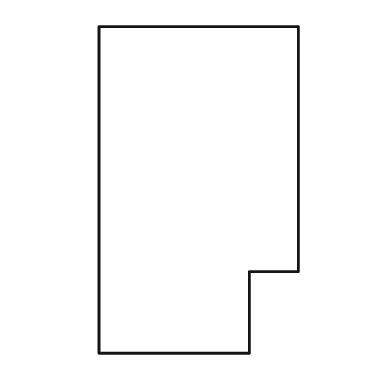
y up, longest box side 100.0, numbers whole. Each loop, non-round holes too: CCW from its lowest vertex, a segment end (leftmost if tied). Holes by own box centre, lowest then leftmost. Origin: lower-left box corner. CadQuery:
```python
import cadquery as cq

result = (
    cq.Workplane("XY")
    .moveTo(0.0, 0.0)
    .lineTo(46.0, 0.0)
    .lineTo(46.0, 25.0)
    .lineTo(61.0, 25.0)
    .lineTo(61.0, 100.0)
    .lineTo(0.0, 100.0)
    .close()
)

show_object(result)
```